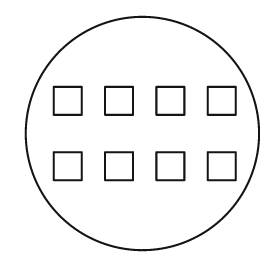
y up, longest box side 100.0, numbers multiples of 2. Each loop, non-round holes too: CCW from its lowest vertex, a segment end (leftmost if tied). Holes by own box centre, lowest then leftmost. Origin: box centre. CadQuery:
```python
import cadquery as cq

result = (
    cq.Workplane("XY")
    .moveTo(0.0, 0.0)
    .circle(50.0)
    .moveTo(-38.0, -20.0)
    .lineTo(-26.0, -20.0)
    .lineTo(-26.0, -8.0)
    .lineTo(-38.0, -8.0)
    .close()
    .moveTo(-16.0, -20.0)
    .lineTo(-4.0, -20.0)
    .lineTo(-4.0, -8.0)
    .lineTo(-16.0, -8.0)
    .close()
    .moveTo(6.0, -20.0)
    .lineTo(18.0, -20.0)
    .lineTo(18.0, -8.0)
    .lineTo(6.0, -8.0)
    .close()
    .moveTo(28.0, -20.0)
    .lineTo(40.0, -20.0)
    .lineTo(40.0, -8.0)
    .lineTo(28.0, -8.0)
    .close()
    .moveTo(-38.0, 8.0)
    .lineTo(-26.0, 8.0)
    .lineTo(-26.0, 20.0)
    .lineTo(-38.0, 20.0)
    .close()
    .moveTo(-16.0, 8.0)
    .lineTo(-4.0, 8.0)
    .lineTo(-4.0, 20.0)
    .lineTo(-16.0, 20.0)
    .close()
    .moveTo(6.0, 8.0)
    .lineTo(18.0, 8.0)
    .lineTo(18.0, 20.0)
    .lineTo(6.0, 20.0)
    .close()
    .moveTo(28.0, 8.0)
    .lineTo(40.0, 8.0)
    .lineTo(40.0, 20.0)
    .lineTo(28.0, 20.0)
    .close()
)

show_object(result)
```